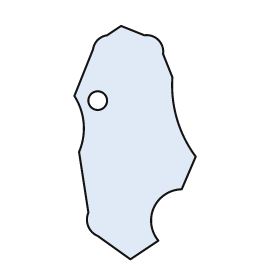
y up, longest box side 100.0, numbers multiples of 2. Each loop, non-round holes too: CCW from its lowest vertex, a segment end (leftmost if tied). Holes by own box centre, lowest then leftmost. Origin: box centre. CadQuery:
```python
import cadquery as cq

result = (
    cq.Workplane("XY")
    .moveTo(-2.0, -50.0)
    .lineTo(10.0, -42.0)
    .threePointArc((8.0, -28.0), (20.0, -20.0))
    .lineTo(26.0, -6.0)
    .threePointArc((18.0, 10.0), (16.0, 28.0))
    .lineTo(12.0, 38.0)
    .threePointArc((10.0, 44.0), (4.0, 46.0))
    .lineTo(-6.0, 50.0)
    .lineTo(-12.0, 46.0)
    .threePointArc((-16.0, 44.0), (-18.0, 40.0))
    .lineTo(-26.0, 20.0)
    .threePointArc((-22.0, 8.0), (-24.0, -4.0))
    .lineTo(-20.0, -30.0)
    .threePointArc((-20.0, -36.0), (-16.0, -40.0))
    .close()
    .moveTo(-16.0, 18.0)
    .circle(4.0)
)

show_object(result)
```